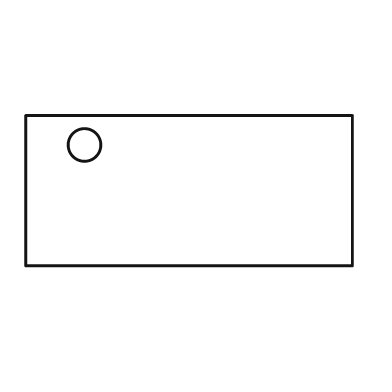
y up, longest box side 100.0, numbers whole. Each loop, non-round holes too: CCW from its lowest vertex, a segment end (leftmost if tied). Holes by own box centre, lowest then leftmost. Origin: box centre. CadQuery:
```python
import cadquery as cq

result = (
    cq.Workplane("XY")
    .moveTo(-50.0, -23.0)
    .lineTo(50.0, -23.0)
    .lineTo(50.0, 23.0)
    .lineTo(-50.0, 23.0)
    .close()
    .moveTo(-32.0, 14.0)
    .circle(5.0)
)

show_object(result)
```